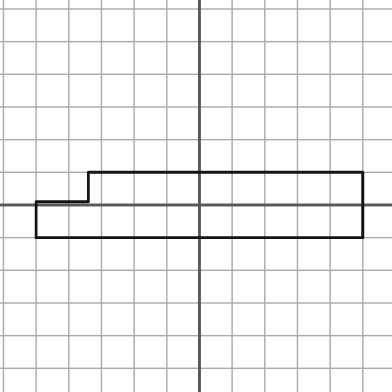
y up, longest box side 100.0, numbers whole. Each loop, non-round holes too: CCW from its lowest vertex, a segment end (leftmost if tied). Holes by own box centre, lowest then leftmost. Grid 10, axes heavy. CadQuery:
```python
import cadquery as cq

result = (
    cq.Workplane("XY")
    .moveTo(-50.0, -10.0)
    .lineTo(50.0, -10.0)
    .lineTo(50.0, 10.0)
    .lineTo(-34.0, 10.0)
    .lineTo(-34.0, 1.0)
    .lineTo(-50.0, 1.0)
    .close()
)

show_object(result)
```